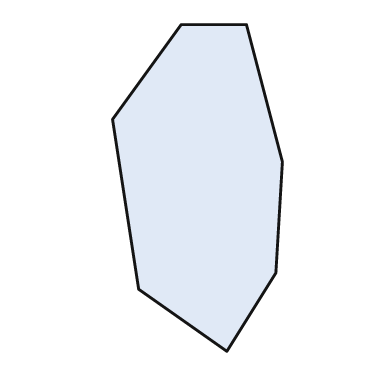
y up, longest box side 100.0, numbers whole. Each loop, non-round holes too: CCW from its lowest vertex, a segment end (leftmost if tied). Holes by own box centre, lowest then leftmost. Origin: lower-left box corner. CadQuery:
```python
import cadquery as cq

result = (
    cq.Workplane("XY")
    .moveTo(35.0, 0.0)
    .lineTo(50.0, 24.0)
    .lineTo(52.0, 58.0)
    .lineTo(41.0, 100.0)
    .lineTo(21.0, 100.0)
    .lineTo(0.0, 71.0)
    .lineTo(8.0, 19.0)
    .close()
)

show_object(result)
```